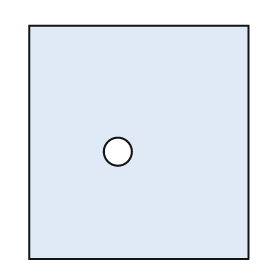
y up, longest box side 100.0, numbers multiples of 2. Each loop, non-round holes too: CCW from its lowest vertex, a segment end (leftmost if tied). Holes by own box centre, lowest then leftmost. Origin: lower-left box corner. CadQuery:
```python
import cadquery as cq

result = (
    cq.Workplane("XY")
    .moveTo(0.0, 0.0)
    .lineTo(94.0, 0.0)
    .lineTo(94.0, 100.0)
    .lineTo(0.0, 100.0)
    .close()
    .moveTo(38.0, 46.0)
    .circle(6.0)
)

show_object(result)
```